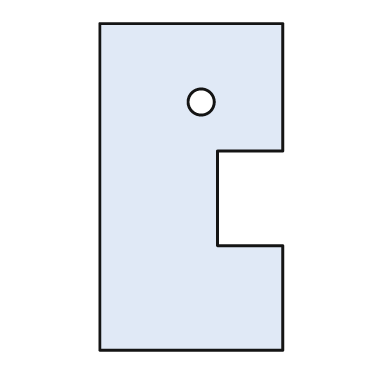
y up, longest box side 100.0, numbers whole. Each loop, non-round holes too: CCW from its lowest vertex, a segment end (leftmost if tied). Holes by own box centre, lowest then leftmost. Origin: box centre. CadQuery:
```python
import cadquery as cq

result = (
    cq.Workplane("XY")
    .moveTo(-28.0, -50.0)
    .lineTo(28.0, -50.0)
    .lineTo(28.0, -18.0)
    .lineTo(8.0, -18.0)
    .lineTo(8.0, 11.0)
    .lineTo(28.0, 11.0)
    .lineTo(28.0, 50.0)
    .lineTo(-28.0, 50.0)
    .close()
    .moveTo(3.0, 26.0)
    .circle(4.0)
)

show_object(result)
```